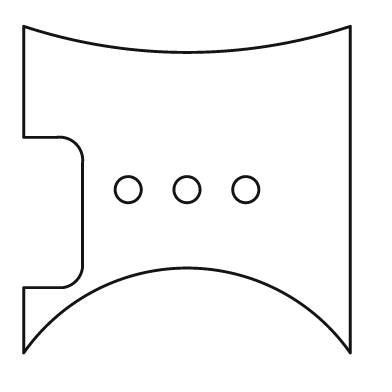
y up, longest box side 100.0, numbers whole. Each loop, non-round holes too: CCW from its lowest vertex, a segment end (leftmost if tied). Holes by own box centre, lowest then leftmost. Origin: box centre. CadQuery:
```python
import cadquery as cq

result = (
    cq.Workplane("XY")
    .moveTo(-50.0, -50.0)
    .threePointArc((0.0, -24.0), (50.0, -50.0))
    .lineTo(50.0, 50.0)
    .threePointArc((0.0, 42.0), (-50.0, 50.0))
    .lineTo(-50.0, 16.0)
    .lineTo(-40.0, 16.0)
    .threePointArc((-34.0, 14.0), (-32.0, 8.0))
    .lineTo(-32.0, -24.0)
    .threePointArc((-34.0, -28.0), (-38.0, -30.0))
    .lineTo(-50.0, -30.0)
    .close()
    .moveTo(-18.0, 0.0)
    .circle(4.0)
    .moveTo(0.0, 0.0)
    .circle(4.0)
    .moveTo(18.0, 0.0)
    .circle(4.0)
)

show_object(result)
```